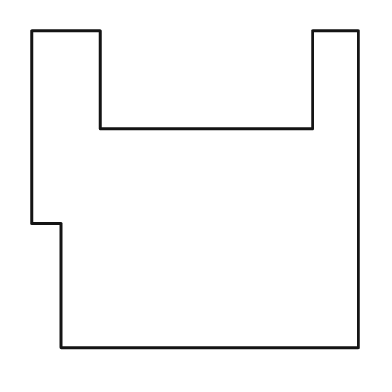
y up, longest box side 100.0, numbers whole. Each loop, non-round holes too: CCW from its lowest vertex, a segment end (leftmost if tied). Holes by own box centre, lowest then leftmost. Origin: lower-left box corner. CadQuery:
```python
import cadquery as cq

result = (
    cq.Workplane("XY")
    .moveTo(9.0, 0.0)
    .lineTo(100.0, 0.0)
    .lineTo(100.0, 97.0)
    .lineTo(86.0, 97.0)
    .lineTo(86.0, 67.0)
    .lineTo(21.0, 67.0)
    .lineTo(21.0, 97.0)
    .lineTo(0.0, 97.0)
    .lineTo(0.0, 38.0)
    .lineTo(9.0, 38.0)
    .close()
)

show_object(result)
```